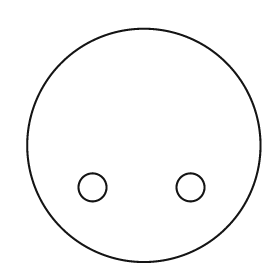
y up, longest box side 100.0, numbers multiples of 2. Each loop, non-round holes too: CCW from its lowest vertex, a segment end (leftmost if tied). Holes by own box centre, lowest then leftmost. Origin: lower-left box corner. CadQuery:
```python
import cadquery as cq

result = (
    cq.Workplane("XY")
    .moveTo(50.0, 50.0)
    .circle(50.0)
    .moveTo(28.0, 32.0)
    .circle(6.0)
    .moveTo(70.0, 32.0)
    .circle(6.0)
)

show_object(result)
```